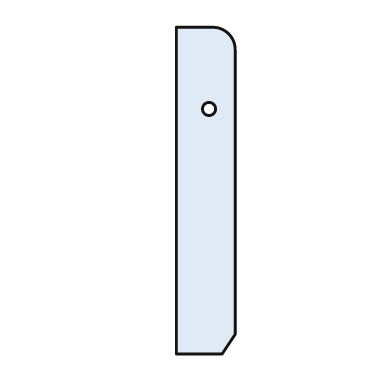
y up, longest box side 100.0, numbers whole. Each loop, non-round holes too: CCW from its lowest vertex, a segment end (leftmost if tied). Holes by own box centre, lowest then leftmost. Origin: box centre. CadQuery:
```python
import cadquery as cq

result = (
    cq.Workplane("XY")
    .moveTo(-9.0, -50.0)
    .lineTo(5.0, -50.0)
    .lineTo(9.0, -44.0)
    .lineTo(9.0, 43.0)
    .threePointArc((7.0, 48.0), (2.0, 50.0))
    .lineTo(-9.0, 50.0)
    .close()
    .moveTo(1.0, 25.0)
    .circle(2.0)
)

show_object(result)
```